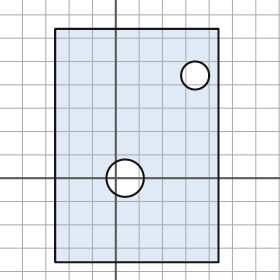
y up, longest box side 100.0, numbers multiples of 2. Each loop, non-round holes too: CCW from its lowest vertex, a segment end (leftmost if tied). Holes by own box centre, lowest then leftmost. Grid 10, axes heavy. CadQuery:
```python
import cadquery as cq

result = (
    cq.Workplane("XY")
    .moveTo(-26.0, -36.0)
    .lineTo(44.0, -36.0)
    .lineTo(44.0, 64.0)
    .lineTo(-26.0, 64.0)
    .close()
    .moveTo(4.0, 0.0)
    .circle(8.0)
    .moveTo(34.0, 44.0)
    .circle(6.0)
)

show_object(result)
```